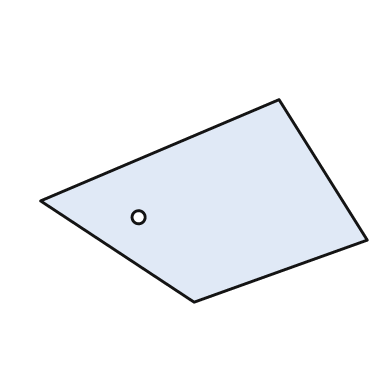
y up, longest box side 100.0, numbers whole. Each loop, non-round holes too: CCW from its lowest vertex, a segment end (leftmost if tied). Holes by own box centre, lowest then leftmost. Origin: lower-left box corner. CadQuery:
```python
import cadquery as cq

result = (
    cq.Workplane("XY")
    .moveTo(47.0, 0.0)
    .lineTo(100.0, 19.0)
    .lineTo(73.0, 62.0)
    .lineTo(0.0, 31.0)
    .close()
    .moveTo(30.0, 26.0)
    .circle(2.0)
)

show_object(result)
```